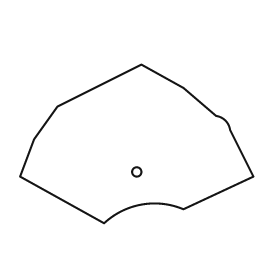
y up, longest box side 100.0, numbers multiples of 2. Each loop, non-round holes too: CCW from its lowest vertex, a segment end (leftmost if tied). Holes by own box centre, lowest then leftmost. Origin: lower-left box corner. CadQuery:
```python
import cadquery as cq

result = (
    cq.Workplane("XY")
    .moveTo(36.0, 0.0)
    .threePointArc((52.0, 8.0), (70.0, 6.0))
    .lineTo(100.0, 20.0)
    .lineTo(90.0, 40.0)
    .threePointArc((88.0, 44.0), (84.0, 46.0))
    .lineTo(70.0, 58.0)
    .lineTo(52.0, 68.0)
    .lineTo(16.0, 50.0)
    .lineTo(6.0, 36.0)
    .lineTo(0.0, 20.0)
    .close()
    .moveTo(50.0, 22.0)
    .circle(2.0)
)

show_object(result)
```